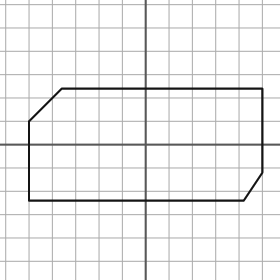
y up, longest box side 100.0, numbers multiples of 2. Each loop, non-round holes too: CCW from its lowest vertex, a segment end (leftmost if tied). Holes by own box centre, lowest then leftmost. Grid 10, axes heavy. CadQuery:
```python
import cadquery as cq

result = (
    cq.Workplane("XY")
    .moveTo(-50.0, -24.0)
    .lineTo(42.0, -24.0)
    .lineTo(50.0, -12.0)
    .lineTo(50.0, 24.0)
    .lineTo(-36.0, 24.0)
    .lineTo(-50.0, 10.0)
    .close()
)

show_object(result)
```